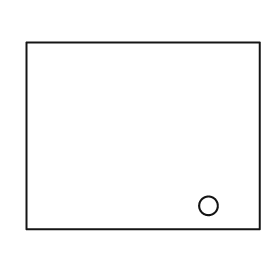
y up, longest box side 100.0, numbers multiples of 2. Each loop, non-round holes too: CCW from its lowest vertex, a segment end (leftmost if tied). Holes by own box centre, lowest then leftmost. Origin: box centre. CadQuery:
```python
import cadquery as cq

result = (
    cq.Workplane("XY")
    .moveTo(-50.0, -40.0)
    .lineTo(50.0, -40.0)
    .lineTo(50.0, 40.0)
    .lineTo(-50.0, 40.0)
    .close()
    .moveTo(28.0, -30.0)
    .circle(4.0)
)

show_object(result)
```